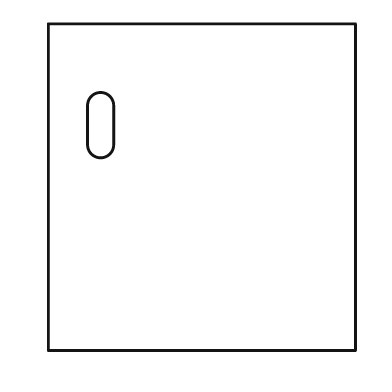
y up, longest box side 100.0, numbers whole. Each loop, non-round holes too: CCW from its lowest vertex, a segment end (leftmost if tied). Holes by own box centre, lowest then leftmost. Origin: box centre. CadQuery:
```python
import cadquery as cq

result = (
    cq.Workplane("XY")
    .moveTo(-47.0, -50.0)
    .lineTo(47.0, -50.0)
    .lineTo(47.0, 50.0)
    .lineTo(-47.0, 50.0)
    .close()
    .moveTo(-35.0, 13.0)
    .threePointArc((-31.0, 9.0), (-27.0, 13.0))
    .lineTo(-27.0, 25.0)
    .threePointArc((-31.0, 29.0), (-35.0, 25.0))
    .close()
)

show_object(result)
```